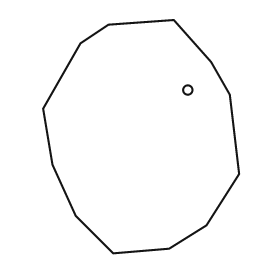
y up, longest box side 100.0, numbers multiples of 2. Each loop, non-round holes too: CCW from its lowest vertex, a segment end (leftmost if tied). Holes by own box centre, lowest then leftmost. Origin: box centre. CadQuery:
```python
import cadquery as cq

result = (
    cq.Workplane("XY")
    .moveTo(-12.0, -50.0)
    .lineTo(12.0, -48.0)
    .lineTo(28.0, -38.0)
    .lineTo(42.0, -16.0)
    .lineTo(38.0, 18.0)
    .lineTo(30.0, 32.0)
    .lineTo(14.0, 50.0)
    .lineTo(-14.0, 48.0)
    .lineTo(-26.0, 40.0)
    .lineTo(-42.0, 12.0)
    .lineTo(-38.0, -12.0)
    .lineTo(-28.0, -34.0)
    .close()
    .moveTo(20.0, 20.0)
    .circle(2.0)
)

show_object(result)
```